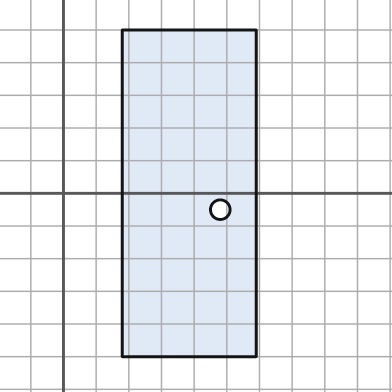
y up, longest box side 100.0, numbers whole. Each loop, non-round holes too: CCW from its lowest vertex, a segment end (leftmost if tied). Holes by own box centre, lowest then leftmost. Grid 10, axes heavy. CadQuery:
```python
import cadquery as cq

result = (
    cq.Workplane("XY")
    .moveTo(18.0, -50.0)
    .lineTo(59.0, -50.0)
    .lineTo(59.0, 50.0)
    .lineTo(18.0, 50.0)
    .close()
    .moveTo(48.0, -5.0)
    .circle(3.0)
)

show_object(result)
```